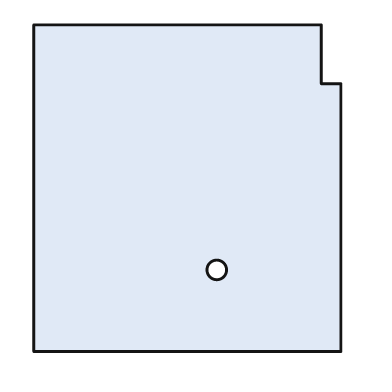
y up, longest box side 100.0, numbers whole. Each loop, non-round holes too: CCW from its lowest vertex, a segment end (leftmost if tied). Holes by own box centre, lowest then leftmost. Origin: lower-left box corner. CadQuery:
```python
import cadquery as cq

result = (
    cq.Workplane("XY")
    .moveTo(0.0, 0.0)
    .lineTo(94.0, 0.0)
    .lineTo(94.0, 82.0)
    .lineTo(88.0, 82.0)
    .lineTo(88.0, 100.0)
    .lineTo(0.0, 100.0)
    .close()
    .moveTo(56.0, 25.0)
    .circle(3.0)
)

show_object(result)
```